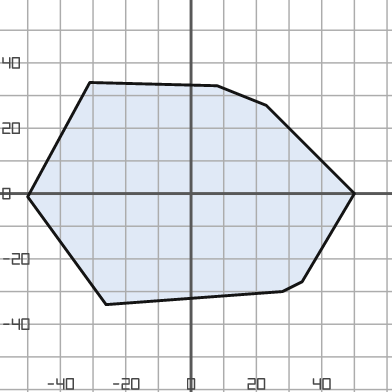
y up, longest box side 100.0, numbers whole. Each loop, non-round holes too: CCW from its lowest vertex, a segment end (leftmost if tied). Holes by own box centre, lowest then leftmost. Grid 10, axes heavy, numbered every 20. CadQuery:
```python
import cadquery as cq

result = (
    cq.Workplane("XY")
    .moveTo(-26.0, -34.0)
    .lineTo(28.0, -30.0)
    .lineTo(34.0, -27.0)
    .lineTo(50.0, 0.0)
    .lineTo(23.0, 27.0)
    .lineTo(8.0, 33.0)
    .lineTo(-31.0, 34.0)
    .lineTo(-50.0, -1.0)
    .close()
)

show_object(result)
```